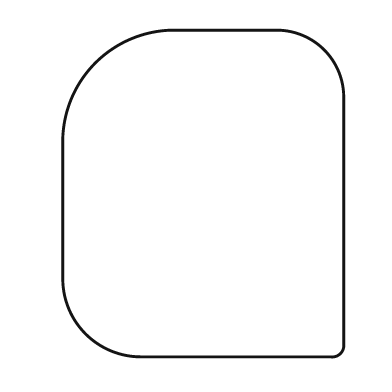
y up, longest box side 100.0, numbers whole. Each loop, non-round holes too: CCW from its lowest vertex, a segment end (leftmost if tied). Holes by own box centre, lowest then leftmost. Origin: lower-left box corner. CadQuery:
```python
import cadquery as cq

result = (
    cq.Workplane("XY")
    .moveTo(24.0, 0.0)
    .lineTo(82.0, 0.0)
    .threePointArc((85.0, 1.0), (86.0, 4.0))
    .lineTo(86.0, 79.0)
    .threePointArc((80.0, 94.0), (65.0, 100.0))
    .lineTo(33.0, 100.0)
    .threePointArc((10.0, 90.0), (0.0, 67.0))
    .lineTo(0.0, 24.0)
    .threePointArc((7.0, 7.0), (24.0, 0.0))
    .close()
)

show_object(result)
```